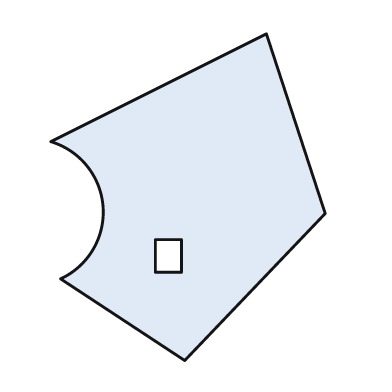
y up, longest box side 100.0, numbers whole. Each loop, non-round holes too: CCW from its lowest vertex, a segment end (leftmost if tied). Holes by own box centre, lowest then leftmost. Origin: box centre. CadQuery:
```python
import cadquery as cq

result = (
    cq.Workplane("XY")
    .moveTo(-1.0, -50.0)
    .lineTo(42.0, -5.0)
    .lineTo(24.0, 50.0)
    .lineTo(-42.0, 17.0)
    .threePointArc((-26.0, -3.0), (-39.0, -25.0))
    .close()
    .moveTo(-10.0, -23.0)
    .lineTo(-2.0, -23.0)
    .lineTo(-2.0, -13.0)
    .lineTo(-10.0, -13.0)
    .close()
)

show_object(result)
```